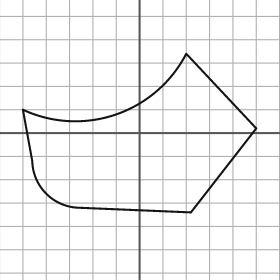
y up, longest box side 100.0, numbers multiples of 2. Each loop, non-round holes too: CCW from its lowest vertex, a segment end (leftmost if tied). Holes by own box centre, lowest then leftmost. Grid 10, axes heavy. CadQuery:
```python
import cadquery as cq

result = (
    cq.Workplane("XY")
    .moveTo(22.0, -34.0)
    .lineTo(50.0, 2.0)
    .lineTo(20.0, 34.0)
    .threePointArc((-10.0, 8.0), (-50.0, 10.0))
    .lineTo(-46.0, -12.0)
    .threePointArc((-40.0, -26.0), (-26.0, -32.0))
    .close()
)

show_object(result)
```